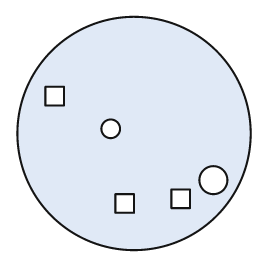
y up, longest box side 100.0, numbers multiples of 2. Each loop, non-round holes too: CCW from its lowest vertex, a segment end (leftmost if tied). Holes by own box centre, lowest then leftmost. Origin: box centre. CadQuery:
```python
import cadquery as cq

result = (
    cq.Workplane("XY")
    .moveTo(0.0, 0.0)
    .circle(50.0)
    .moveTo(-8.0, -34.0)
    .lineTo(0.0, -34.0)
    .lineTo(0.0, -26.0)
    .lineTo(-8.0, -26.0)
    .close()
    .moveTo(16.0, -32.0)
    .lineTo(24.0, -32.0)
    .lineTo(24.0, -24.0)
    .lineTo(16.0, -24.0)
    .close()
    .moveTo(34.0, -20.0)
    .circle(6.0)
    .moveTo(-10.0, 2.0)
    .circle(4.0)
    .moveTo(-38.0, 12.0)
    .lineTo(-30.0, 12.0)
    .lineTo(-30.0, 20.0)
    .lineTo(-38.0, 20.0)
    .close()
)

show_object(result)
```